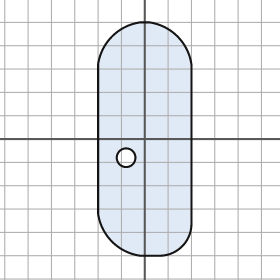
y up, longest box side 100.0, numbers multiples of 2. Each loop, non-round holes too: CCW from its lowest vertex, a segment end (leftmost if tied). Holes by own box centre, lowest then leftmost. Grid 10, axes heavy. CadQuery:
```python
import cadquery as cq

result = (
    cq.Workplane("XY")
    .moveTo(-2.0, -50.0)
    .lineTo(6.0, -50.0)
    .threePointArc((16.0, -46.0), (20.0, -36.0))
    .lineTo(20.0, 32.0)
    .threePointArc((14.0, 44.0), (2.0, 50.0))
    .lineTo(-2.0, 50.0)
    .threePointArc((-14.0, 44.0), (-20.0, 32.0))
    .lineTo(-20.0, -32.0)
    .threePointArc((-14.0, -44.0), (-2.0, -50.0))
    .close()
    .moveTo(-8.0, -8.0)
    .circle(4.0)
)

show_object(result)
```